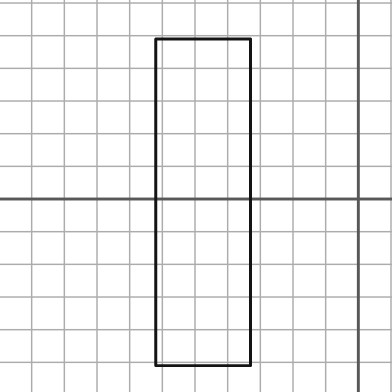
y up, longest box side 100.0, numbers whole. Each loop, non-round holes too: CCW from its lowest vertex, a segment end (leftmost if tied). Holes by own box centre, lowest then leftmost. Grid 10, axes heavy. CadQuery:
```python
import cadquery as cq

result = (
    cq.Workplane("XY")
    .moveTo(-62.0, -51.0)
    .lineTo(-33.0, -51.0)
    .lineTo(-33.0, 49.0)
    .lineTo(-62.0, 49.0)
    .close()
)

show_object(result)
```